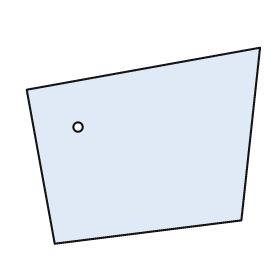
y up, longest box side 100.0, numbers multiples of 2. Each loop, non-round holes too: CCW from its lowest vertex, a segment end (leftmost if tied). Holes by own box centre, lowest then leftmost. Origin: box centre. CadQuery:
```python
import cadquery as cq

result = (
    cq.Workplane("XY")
    .moveTo(-38.0, -42.0)
    .lineTo(42.0, -32.0)
    .lineTo(50.0, 42.0)
    .lineTo(-50.0, 24.0)
    .close()
    .moveTo(-28.0, 8.0)
    .circle(2.0)
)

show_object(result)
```